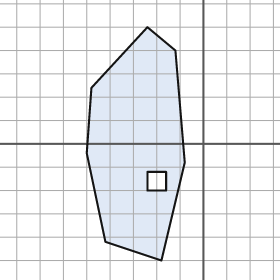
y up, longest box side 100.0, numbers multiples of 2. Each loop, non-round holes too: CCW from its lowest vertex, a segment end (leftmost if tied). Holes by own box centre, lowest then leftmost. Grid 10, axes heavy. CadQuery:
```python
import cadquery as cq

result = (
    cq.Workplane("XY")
    .moveTo(-18.0, -50.0)
    .lineTo(-8.0, -8.0)
    .lineTo(-12.0, 40.0)
    .lineTo(-24.0, 50.0)
    .lineTo(-48.0, 24.0)
    .lineTo(-50.0, -4.0)
    .lineTo(-42.0, -42.0)
    .close()
    .moveTo(-24.0, -20.0)
    .lineTo(-16.0, -20.0)
    .lineTo(-16.0, -12.0)
    .lineTo(-24.0, -12.0)
    .close()
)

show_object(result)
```